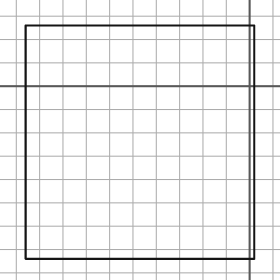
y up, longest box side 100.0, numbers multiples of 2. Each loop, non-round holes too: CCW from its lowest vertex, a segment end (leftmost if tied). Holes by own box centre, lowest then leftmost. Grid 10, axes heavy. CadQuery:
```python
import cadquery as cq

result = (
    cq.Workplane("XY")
    .moveTo(-96.0, -74.0)
    .lineTo(2.0, -74.0)
    .lineTo(2.0, 26.0)
    .lineTo(-96.0, 26.0)
    .close()
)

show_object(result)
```